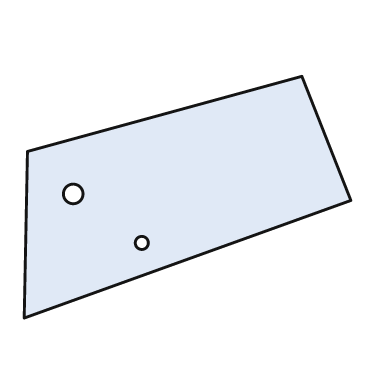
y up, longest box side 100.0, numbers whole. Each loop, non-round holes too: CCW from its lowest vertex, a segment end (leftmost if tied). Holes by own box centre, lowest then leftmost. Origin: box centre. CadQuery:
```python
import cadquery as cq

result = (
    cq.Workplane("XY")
    .moveTo(-50.0, -37.0)
    .lineTo(50.0, -1.0)
    .lineTo(35.0, 37.0)
    .lineTo(-49.0, 14.0)
    .close()
    .moveTo(-14.0, -14.0)
    .circle(2.0)
    .moveTo(-35.0, 1.0)
    .circle(3.0)
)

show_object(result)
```